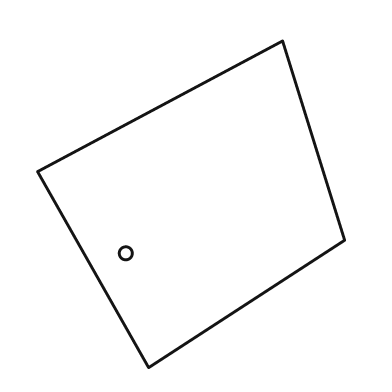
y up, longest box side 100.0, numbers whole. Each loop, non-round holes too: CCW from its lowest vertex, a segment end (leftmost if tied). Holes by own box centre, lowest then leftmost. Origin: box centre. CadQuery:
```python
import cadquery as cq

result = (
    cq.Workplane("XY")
    .moveTo(-13.0, -50.0)
    .lineTo(47.0, -11.0)
    .lineTo(28.0, 50.0)
    .lineTo(-47.0, 10.0)
    .close()
    .moveTo(-20.0, -15.0)
    .circle(2.0)
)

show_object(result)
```